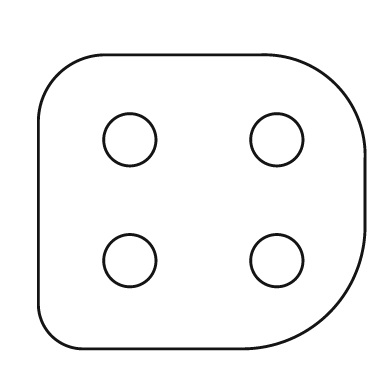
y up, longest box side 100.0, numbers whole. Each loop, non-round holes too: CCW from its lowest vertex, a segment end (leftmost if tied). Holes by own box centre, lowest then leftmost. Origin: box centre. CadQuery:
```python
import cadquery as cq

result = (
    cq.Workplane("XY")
    .moveTo(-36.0, -45.0)
    .lineTo(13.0, -45.0)
    .threePointArc((39.0, -34.0), (50.0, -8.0))
    .lineTo(50.0, 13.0)
    .threePointArc((41.0, 36.0), (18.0, 45.0))
    .lineTo(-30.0, 45.0)
    .threePointArc((-44.0, 39.0), (-50.0, 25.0))
    .lineTo(-50.0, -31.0)
    .threePointArc((-46.0, -41.0), (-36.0, -45.0))
    .close()
    .moveTo(-22.0, -18.0)
    .circle(8.0)
    .moveTo(23.0, -18.0)
    .circle(8.0)
    .moveTo(-22.0, 19.0)
    .circle(8.0)
    .moveTo(23.0, 19.0)
    .circle(8.0)
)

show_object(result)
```